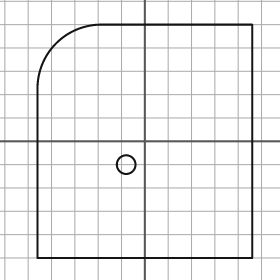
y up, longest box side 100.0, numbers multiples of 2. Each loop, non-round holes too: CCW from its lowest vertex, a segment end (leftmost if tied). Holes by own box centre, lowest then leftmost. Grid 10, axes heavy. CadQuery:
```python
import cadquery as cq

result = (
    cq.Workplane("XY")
    .moveTo(-46.0, -50.0)
    .lineTo(46.0, -50.0)
    .lineTo(46.0, 50.0)
    .lineTo(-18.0, 50.0)
    .threePointArc((-38.0, 42.0), (-46.0, 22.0))
    .close()
    .moveTo(-8.0, -10.0)
    .circle(4.0)
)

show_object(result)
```